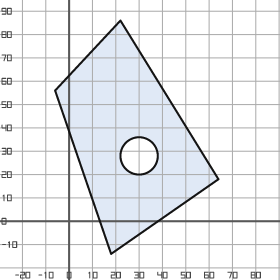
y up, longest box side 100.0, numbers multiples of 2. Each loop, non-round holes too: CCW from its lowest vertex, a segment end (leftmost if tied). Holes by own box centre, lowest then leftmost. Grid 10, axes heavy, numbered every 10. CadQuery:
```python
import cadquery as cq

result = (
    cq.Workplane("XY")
    .moveTo(18.0, -14.0)
    .lineTo(64.0, 18.0)
    .lineTo(22.0, 86.0)
    .lineTo(-6.0, 56.0)
    .close()
    .moveTo(30.0, 28.0)
    .circle(8.0)
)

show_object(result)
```